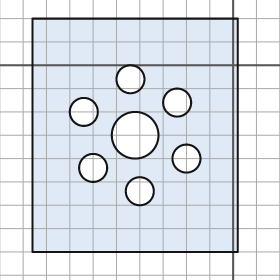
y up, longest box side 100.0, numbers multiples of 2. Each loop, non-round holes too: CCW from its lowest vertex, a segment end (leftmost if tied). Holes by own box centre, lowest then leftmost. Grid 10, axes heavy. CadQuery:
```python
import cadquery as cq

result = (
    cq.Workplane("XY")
    .moveTo(-86.0, -80.0)
    .lineTo(2.0, -80.0)
    .lineTo(2.0, 20.0)
    .lineTo(-86.0, 20.0)
    .close()
    .moveTo(-40.0, -54.0)
    .circle(6.0)
    .moveTo(-60.0, -44.0)
    .circle(6.0)
    .moveTo(-20.0, -40.0)
    .circle(6.0)
    .moveTo(-42.0, -30.0)
    .circle(10.0)
    .moveTo(-64.0, -20.0)
    .circle(6.0)
    .moveTo(-24.0, -16.0)
    .circle(6.0)
    .moveTo(-44.0, -6.0)
    .circle(6.0)
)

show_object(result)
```